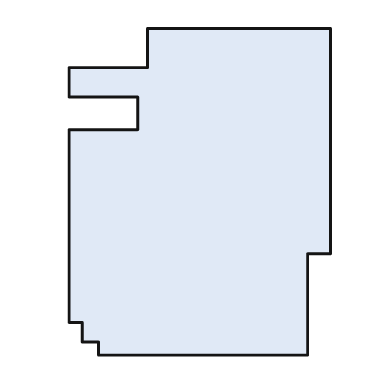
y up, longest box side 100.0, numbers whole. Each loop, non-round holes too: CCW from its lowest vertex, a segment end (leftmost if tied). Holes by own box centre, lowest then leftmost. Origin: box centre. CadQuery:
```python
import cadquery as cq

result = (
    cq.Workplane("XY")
    .moveTo(-31.0, -50.0)
    .lineTo(33.0, -50.0)
    .lineTo(33.0, -19.0)
    .lineTo(40.0, -19.0)
    .lineTo(40.0, 50.0)
    .lineTo(-16.0, 50.0)
    .lineTo(-16.0, 38.0)
    .lineTo(-40.0, 38.0)
    .lineTo(-40.0, 29.0)
    .lineTo(-19.0, 29.0)
    .lineTo(-19.0, 19.0)
    .lineTo(-40.0, 19.0)
    .lineTo(-40.0, -40.0)
    .lineTo(-36.0, -40.0)
    .lineTo(-36.0, -46.0)
    .lineTo(-31.0, -46.0)
    .close()
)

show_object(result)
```